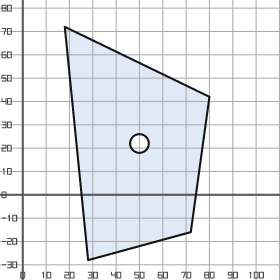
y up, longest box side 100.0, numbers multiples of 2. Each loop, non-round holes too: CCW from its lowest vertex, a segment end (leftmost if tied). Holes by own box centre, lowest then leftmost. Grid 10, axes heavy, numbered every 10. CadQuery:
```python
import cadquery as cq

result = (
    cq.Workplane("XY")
    .moveTo(28.0, -28.0)
    .lineTo(72.0, -16.0)
    .lineTo(80.0, 42.0)
    .lineTo(18.0, 72.0)
    .close()
    .moveTo(50.0, 22.0)
    .circle(4.0)
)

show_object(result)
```